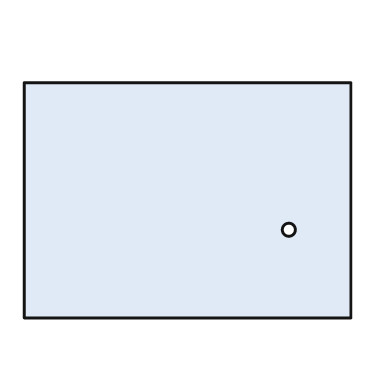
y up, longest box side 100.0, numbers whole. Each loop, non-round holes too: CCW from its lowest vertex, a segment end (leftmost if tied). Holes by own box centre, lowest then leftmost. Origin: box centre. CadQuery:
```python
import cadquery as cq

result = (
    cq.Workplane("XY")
    .moveTo(-50.0, -36.0)
    .lineTo(50.0, -36.0)
    .lineTo(50.0, 36.0)
    .lineTo(-50.0, 36.0)
    .close()
    .moveTo(31.0, -9.0)
    .circle(2.0)
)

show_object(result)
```